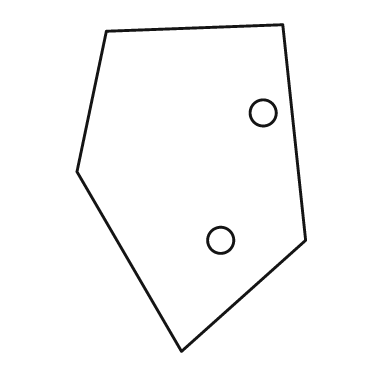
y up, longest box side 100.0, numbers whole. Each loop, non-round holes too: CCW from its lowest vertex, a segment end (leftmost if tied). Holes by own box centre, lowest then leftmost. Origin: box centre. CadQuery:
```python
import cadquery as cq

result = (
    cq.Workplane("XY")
    .moveTo(-3.0, -50.0)
    .lineTo(35.0, -16.0)
    .lineTo(28.0, 50.0)
    .lineTo(-26.0, 48.0)
    .lineTo(-35.0, 5.0)
    .close()
    .moveTo(9.0, -16.0)
    .circle(4.0)
    .moveTo(22.0, 23.0)
    .circle(4.0)
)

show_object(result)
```